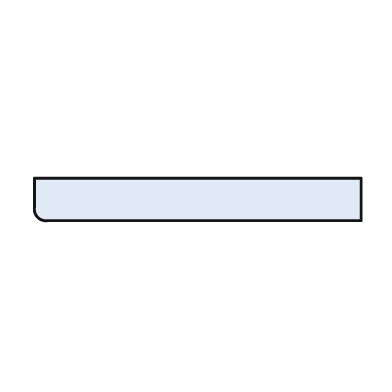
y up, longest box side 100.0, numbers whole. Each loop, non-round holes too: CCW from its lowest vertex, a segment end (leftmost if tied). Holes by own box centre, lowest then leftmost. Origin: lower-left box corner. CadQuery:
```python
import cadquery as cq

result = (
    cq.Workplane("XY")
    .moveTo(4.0, 0.0)
    .lineTo(100.0, 0.0)
    .lineTo(100.0, 13.0)
    .lineTo(0.0, 13.0)
    .lineTo(0.0, 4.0)
    .threePointArc((1.0, 1.0), (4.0, 0.0))
    .close()
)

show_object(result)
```